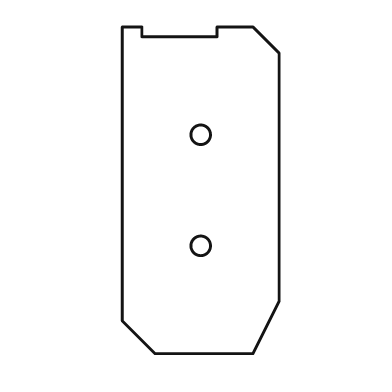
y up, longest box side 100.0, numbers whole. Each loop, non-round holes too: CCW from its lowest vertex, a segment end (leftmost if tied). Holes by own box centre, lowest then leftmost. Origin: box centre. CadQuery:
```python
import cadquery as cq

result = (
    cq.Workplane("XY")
    .moveTo(-14.0, -50.0)
    .lineTo(16.0, -50.0)
    .lineTo(24.0, -34.0)
    .lineTo(24.0, 42.0)
    .lineTo(16.0, 50.0)
    .lineTo(5.0, 50.0)
    .lineTo(5.0, 47.0)
    .lineTo(-18.0, 47.0)
    .lineTo(-18.0, 50.0)
    .lineTo(-24.0, 50.0)
    .lineTo(-24.0, -40.0)
    .close()
    .moveTo(0.0, -17.0)
    .circle(3.0)
    .moveTo(0.0, 17.0)
    .circle(3.0)
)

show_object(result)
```